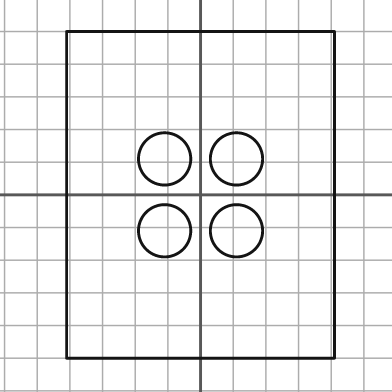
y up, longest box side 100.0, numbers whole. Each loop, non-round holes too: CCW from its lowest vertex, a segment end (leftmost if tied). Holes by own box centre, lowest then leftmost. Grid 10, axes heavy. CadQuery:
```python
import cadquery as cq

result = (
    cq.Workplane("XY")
    .moveTo(-41.0, -50.0)
    .lineTo(41.0, -50.0)
    .lineTo(41.0, 50.0)
    .lineTo(-41.0, 50.0)
    .close()
    .moveTo(-11.0, -11.0)
    .circle(8.0)
    .moveTo(11.0, -11.0)
    .circle(8.0)
    .moveTo(-11.0, 11.0)
    .circle(8.0)
    .moveTo(11.0, 11.0)
    .circle(8.0)
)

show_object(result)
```